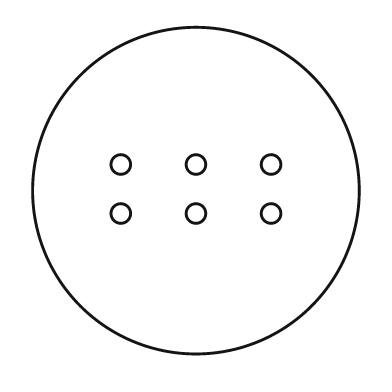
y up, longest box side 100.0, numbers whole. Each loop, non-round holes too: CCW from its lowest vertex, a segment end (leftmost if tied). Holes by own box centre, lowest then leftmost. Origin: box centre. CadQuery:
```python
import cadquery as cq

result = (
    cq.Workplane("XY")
    .moveTo(0.0, 0.0)
    .circle(50.0)
    .moveTo(-23.0, -7.0)
    .circle(3.0)
    .moveTo(0.0, -7.0)
    .circle(3.0)
    .moveTo(23.0, -7.0)
    .circle(3.0)
    .moveTo(-23.0, 8.0)
    .circle(3.0)
    .moveTo(0.0, 8.0)
    .circle(3.0)
    .moveTo(23.0, 8.0)
    .circle(3.0)
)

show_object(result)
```